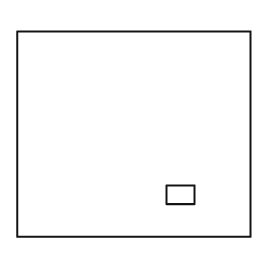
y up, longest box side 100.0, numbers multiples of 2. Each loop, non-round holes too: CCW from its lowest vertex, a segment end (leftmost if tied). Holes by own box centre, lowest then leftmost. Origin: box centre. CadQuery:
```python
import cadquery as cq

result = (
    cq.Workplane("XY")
    .moveTo(-50.0, -44.0)
    .lineTo(50.0, -44.0)
    .lineTo(50.0, 44.0)
    .lineTo(-50.0, 44.0)
    .close()
    .moveTo(14.0, -30.0)
    .lineTo(26.0, -30.0)
    .lineTo(26.0, -22.0)
    .lineTo(14.0, -22.0)
    .close()
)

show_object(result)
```